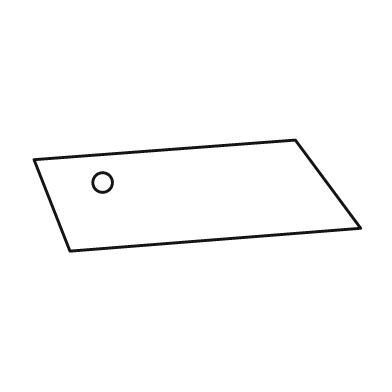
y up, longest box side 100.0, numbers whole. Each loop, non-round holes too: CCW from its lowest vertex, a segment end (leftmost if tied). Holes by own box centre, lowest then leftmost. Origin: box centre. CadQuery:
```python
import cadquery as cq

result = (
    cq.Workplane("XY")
    .moveTo(-39.0, -17.0)
    .lineTo(50.0, -10.0)
    .lineTo(30.0, 17.0)
    .lineTo(-50.0, 11.0)
    .close()
    .moveTo(-29.0, 4.0)
    .circle(3.0)
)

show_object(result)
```